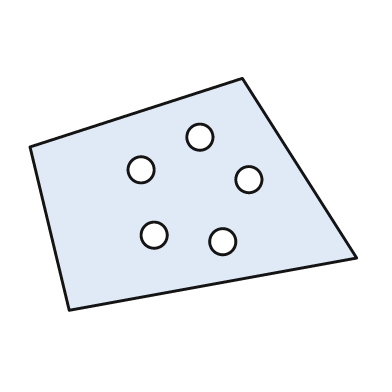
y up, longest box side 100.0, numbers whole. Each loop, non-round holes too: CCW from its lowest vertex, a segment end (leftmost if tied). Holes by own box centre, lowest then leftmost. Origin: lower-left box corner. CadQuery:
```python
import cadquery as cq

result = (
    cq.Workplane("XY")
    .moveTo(12.0, 0.0)
    .lineTo(100.0, 16.0)
    .lineTo(65.0, 71.0)
    .lineTo(0.0, 50.0)
    .close()
    .moveTo(59.0, 21.0)
    .circle(4.0)
    .moveTo(38.0, 23.0)
    .circle(4.0)
    .moveTo(67.0, 40.0)
    .circle(4.0)
    .moveTo(34.0, 43.0)
    .circle(4.0)
    .moveTo(52.0, 53.0)
    .circle(4.0)
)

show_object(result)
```